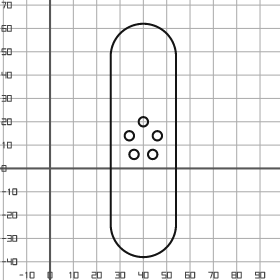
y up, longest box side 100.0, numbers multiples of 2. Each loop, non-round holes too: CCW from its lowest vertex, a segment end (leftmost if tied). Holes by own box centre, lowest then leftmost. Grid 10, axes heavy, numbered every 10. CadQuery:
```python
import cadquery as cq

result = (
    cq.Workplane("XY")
    .moveTo(26.0, -24.0)
    .threePointArc((40.0, -38.0), (54.0, -24.0))
    .lineTo(54.0, 48.0)
    .threePointArc((40.0, 62.0), (26.0, 48.0))
    .close()
    .moveTo(36.0, 6.0)
    .circle(2.0)
    .moveTo(44.0, 6.0)
    .circle(2.0)
    .moveTo(34.0, 14.0)
    .circle(2.0)
    .moveTo(46.0, 14.0)
    .circle(2.0)
    .moveTo(40.0, 20.0)
    .circle(2.0)
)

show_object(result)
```